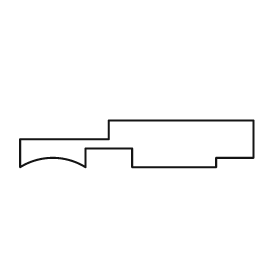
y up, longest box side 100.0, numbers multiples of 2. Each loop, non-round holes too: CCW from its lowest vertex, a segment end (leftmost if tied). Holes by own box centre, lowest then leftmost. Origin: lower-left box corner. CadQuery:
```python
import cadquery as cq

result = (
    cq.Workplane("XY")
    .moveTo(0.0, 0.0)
    .threePointArc((14.0, 4.0), (28.0, 0.0))
    .lineTo(28.0, 8.0)
    .lineTo(48.0, 8.0)
    .lineTo(48.0, 0.0)
    .lineTo(84.0, 0.0)
    .lineTo(84.0, 4.0)
    .lineTo(100.0, 4.0)
    .lineTo(100.0, 20.0)
    .lineTo(38.0, 20.0)
    .lineTo(38.0, 12.0)
    .lineTo(0.0, 12.0)
    .close()
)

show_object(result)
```